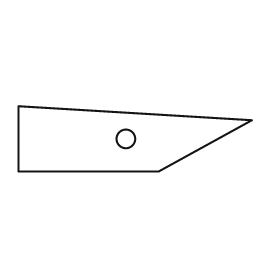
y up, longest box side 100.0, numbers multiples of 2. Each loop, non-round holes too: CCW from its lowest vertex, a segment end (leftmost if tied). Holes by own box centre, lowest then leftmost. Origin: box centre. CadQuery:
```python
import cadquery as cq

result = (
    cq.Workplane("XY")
    .moveTo(-50.0, -14.0)
    .lineTo(10.0, -14.0)
    .lineTo(50.0, 8.0)
    .lineTo(-50.0, 14.0)
    .close()
    .moveTo(-4.0, 0.0)
    .circle(4.0)
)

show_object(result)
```